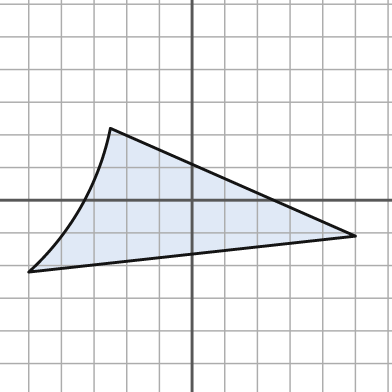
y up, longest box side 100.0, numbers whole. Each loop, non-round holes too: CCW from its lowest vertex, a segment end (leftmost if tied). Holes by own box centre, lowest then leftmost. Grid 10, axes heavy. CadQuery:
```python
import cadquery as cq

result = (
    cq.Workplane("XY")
    .moveTo(-50.0, -22.0)
    .lineTo(50.0, -11.0)
    .lineTo(-25.0, 22.0)
    .threePointArc((-34.0, -2.0), (-50.0, -22.0))
    .close()
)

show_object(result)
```